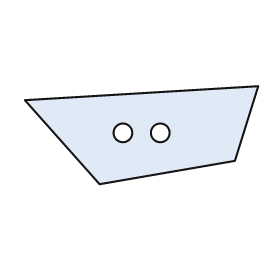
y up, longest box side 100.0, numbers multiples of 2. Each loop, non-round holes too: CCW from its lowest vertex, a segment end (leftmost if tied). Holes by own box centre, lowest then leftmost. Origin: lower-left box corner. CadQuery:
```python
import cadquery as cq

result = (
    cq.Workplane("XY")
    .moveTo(32.0, 0.0)
    .lineTo(90.0, 10.0)
    .lineTo(100.0, 42.0)
    .lineTo(0.0, 36.0)
    .close()
    .moveTo(42.0, 22.0)
    .circle(4.0)
    .moveTo(58.0, 22.0)
    .circle(4.0)
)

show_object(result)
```